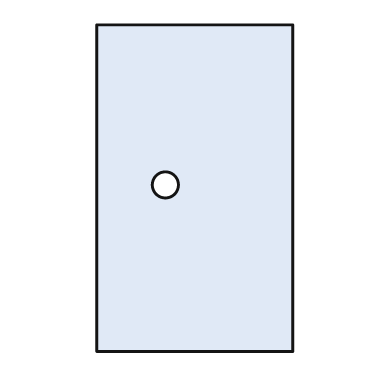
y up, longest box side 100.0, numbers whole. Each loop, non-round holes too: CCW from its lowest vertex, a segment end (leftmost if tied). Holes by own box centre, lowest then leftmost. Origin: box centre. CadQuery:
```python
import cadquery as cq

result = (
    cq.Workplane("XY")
    .moveTo(-30.0, -50.0)
    .lineTo(30.0, -50.0)
    .lineTo(30.0, 50.0)
    .lineTo(-30.0, 50.0)
    .close()
    .moveTo(-9.0, 1.0)
    .circle(4.0)
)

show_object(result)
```